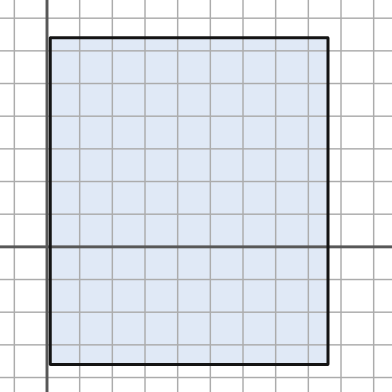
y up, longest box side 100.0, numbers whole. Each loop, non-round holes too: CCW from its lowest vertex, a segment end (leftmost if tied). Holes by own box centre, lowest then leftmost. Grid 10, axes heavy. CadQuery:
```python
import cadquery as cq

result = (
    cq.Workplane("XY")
    .moveTo(1.0, -36.0)
    .lineTo(86.0, -36.0)
    .lineTo(86.0, 64.0)
    .lineTo(1.0, 64.0)
    .close()
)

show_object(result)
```